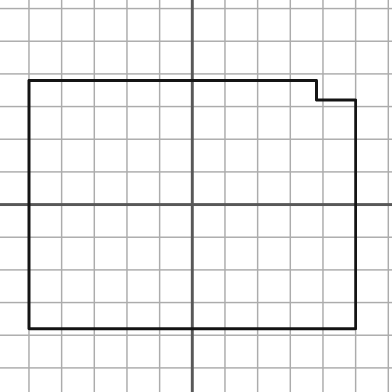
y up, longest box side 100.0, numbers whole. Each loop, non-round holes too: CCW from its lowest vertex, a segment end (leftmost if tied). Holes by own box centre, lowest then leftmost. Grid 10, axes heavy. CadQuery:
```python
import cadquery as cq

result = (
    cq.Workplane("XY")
    .moveTo(-50.0, -38.0)
    .lineTo(50.0, -38.0)
    .lineTo(50.0, 32.0)
    .lineTo(38.0, 32.0)
    .lineTo(38.0, 38.0)
    .lineTo(-50.0, 38.0)
    .close()
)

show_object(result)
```